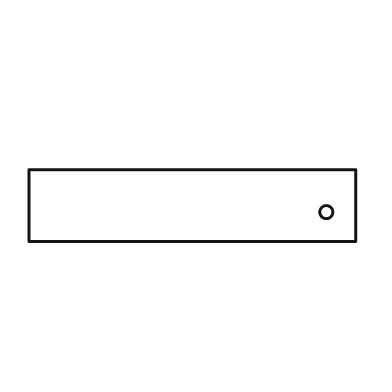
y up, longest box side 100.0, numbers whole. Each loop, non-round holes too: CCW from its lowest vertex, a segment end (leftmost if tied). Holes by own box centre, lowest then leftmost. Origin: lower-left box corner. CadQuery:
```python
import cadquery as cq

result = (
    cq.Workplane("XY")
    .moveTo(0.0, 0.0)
    .lineTo(100.0, 0.0)
    .lineTo(100.0, 22.0)
    .lineTo(0.0, 22.0)
    .close()
    .moveTo(91.0, 9.0)
    .circle(2.0)
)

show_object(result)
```